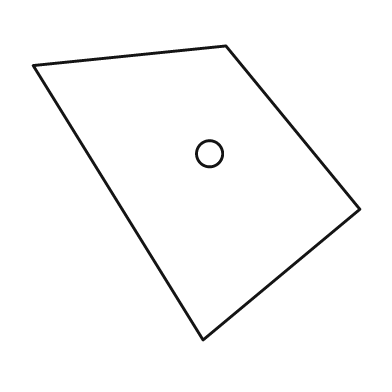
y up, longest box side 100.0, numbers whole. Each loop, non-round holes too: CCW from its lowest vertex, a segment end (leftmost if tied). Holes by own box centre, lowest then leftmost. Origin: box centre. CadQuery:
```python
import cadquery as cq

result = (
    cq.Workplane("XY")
    .moveTo(2.0, -45.0)
    .lineTo(50.0, -5.0)
    .lineTo(9.0, 45.0)
    .lineTo(-50.0, 39.0)
    .close()
    .moveTo(4.0, 12.0)
    .circle(4.0)
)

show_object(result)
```